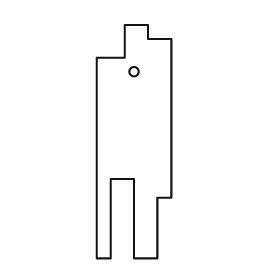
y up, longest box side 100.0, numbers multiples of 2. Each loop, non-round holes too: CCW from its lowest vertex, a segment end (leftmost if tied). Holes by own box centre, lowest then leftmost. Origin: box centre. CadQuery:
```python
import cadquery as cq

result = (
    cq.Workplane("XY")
    .moveTo(-16.0, -50.0)
    .lineTo(-10.0, -50.0)
    .lineTo(-10.0, -16.0)
    .lineTo(0.0, -16.0)
    .lineTo(0.0, -50.0)
    .lineTo(10.0, -50.0)
    .lineTo(10.0, -24.0)
    .lineTo(16.0, -24.0)
    .lineTo(16.0, 44.0)
    .lineTo(6.0, 44.0)
    .lineTo(6.0, 50.0)
    .lineTo(-4.0, 50.0)
    .lineTo(-4.0, 36.0)
    .lineTo(-16.0, 36.0)
    .close()
    .moveTo(0.0, 30.0)
    .circle(2.0)
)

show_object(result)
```